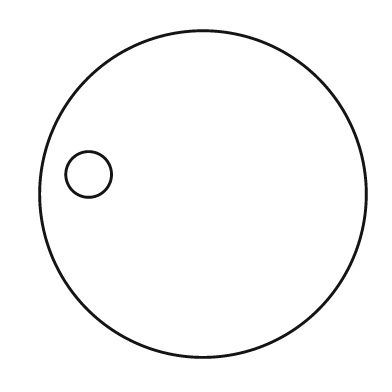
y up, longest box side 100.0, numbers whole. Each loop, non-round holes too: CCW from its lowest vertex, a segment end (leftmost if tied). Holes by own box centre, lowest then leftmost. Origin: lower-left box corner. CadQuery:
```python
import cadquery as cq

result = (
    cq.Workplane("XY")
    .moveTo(50.0, 50.0)
    .circle(50.0)
    .moveTo(15.0, 56.0)
    .circle(7.0)
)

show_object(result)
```